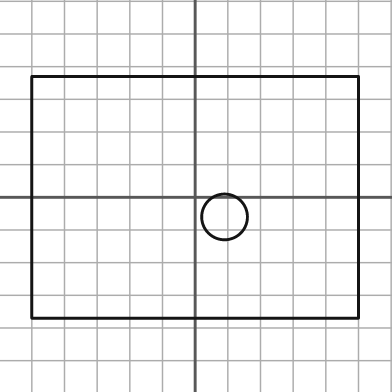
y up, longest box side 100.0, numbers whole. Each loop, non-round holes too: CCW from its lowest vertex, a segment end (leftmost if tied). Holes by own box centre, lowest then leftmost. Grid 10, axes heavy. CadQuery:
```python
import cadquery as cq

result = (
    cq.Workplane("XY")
    .moveTo(-50.0, -37.0)
    .lineTo(50.0, -37.0)
    .lineTo(50.0, 37.0)
    .lineTo(-50.0, 37.0)
    .close()
    .moveTo(9.0, -6.0)
    .circle(7.0)
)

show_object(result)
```